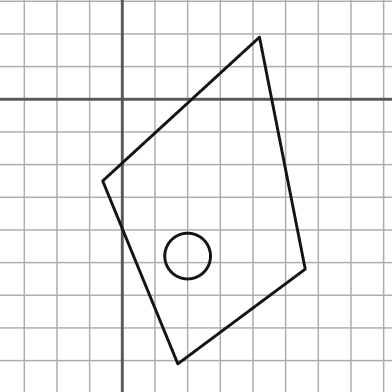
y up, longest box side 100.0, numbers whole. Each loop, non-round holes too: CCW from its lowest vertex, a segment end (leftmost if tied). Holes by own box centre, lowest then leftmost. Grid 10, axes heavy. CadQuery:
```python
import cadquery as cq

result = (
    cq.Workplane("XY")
    .moveTo(17.0, -81.0)
    .lineTo(56.0, -52.0)
    .lineTo(42.0, 19.0)
    .lineTo(-6.0, -25.0)
    .close()
    .moveTo(20.0, -48.0)
    .circle(7.0)
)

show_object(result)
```